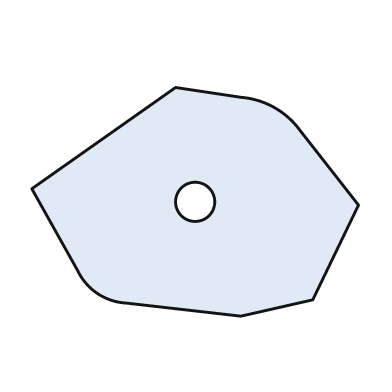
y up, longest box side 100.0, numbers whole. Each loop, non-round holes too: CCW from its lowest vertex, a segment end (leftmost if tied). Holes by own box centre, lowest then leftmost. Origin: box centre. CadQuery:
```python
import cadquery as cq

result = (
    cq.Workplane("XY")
    .moveTo(14.0, -35.0)
    .lineTo(36.0, -30.0)
    .lineTo(50.0, -1.0)
    .lineTo(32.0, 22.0)
    .threePointArc((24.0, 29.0), (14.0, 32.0))
    .lineTo(-6.0, 35.0)
    .lineTo(-50.0, 4.0)
    .lineTo(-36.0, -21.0)
    .threePointArc((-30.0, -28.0), (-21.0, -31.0))
    .close()
    .moveTo(0.0, 0.0)
    .circle(6.0)
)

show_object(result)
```